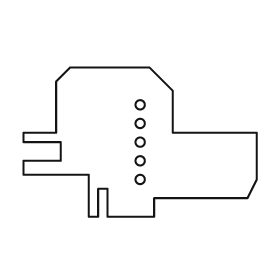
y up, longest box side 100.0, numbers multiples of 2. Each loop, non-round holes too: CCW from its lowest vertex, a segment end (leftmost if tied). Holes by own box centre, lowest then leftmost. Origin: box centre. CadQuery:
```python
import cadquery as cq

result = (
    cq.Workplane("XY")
    .moveTo(-22.0, -32.0)
    .lineTo(-18.0, -32.0)
    .lineTo(-18.0, -20.0)
    .lineTo(-14.0, -20.0)
    .lineTo(-14.0, -32.0)
    .lineTo(6.0, -32.0)
    .lineTo(6.0, -24.0)
    .lineTo(46.0, -24.0)
    .lineTo(50.0, -16.0)
    .lineTo(50.0, 4.0)
    .lineTo(14.0, 4.0)
    .lineTo(14.0, 22.0)
    .lineTo(4.0, 32.0)
    .lineTo(-30.0, 32.0)
    .lineTo(-36.0, 26.0)
    .lineTo(-36.0, 4.0)
    .lineTo(-50.0, 4.0)
    .lineTo(-50.0, 0.0)
    .lineTo(-34.0, 0.0)
    .lineTo(-34.0, -8.0)
    .lineTo(-50.0, -8.0)
    .lineTo(-50.0, -14.0)
    .lineTo(-22.0, -14.0)
    .close()
    .moveTo(0.0, -16.0)
    .circle(2.0)
    .moveTo(0.0, -8.0)
    .circle(2.0)
    .moveTo(0.0, 0.0)
    .circle(2.0)
    .moveTo(0.0, 8.0)
    .circle(2.0)
    .moveTo(0.0, 16.0)
    .circle(2.0)
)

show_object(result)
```